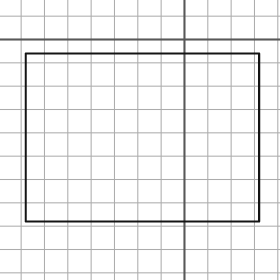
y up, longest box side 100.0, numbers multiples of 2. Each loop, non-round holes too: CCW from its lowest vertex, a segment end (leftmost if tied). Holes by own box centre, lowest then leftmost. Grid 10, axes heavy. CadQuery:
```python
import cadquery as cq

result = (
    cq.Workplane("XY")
    .moveTo(-68.0, -78.0)
    .lineTo(32.0, -78.0)
    .lineTo(32.0, -6.0)
    .lineTo(-68.0, -6.0)
    .close()
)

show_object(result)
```